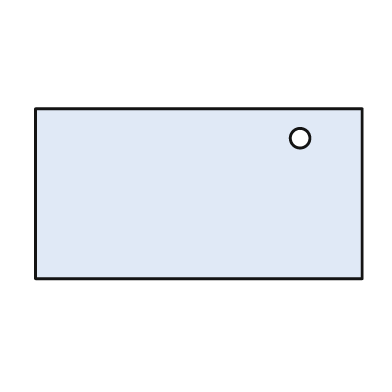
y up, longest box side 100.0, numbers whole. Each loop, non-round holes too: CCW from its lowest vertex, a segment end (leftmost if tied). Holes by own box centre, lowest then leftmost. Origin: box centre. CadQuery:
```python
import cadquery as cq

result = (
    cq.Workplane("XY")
    .moveTo(-50.0, -26.0)
    .lineTo(50.0, -26.0)
    .lineTo(50.0, 26.0)
    .lineTo(-50.0, 26.0)
    .close()
    .moveTo(31.0, 17.0)
    .circle(3.0)
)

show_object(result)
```